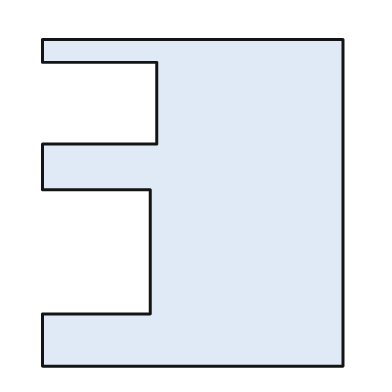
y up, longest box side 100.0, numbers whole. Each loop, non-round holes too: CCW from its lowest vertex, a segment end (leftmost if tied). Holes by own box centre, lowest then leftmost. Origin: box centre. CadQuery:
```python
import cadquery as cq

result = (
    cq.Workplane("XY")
    .moveTo(-46.0, -50.0)
    .lineTo(46.0, -50.0)
    .lineTo(46.0, 50.0)
    .lineTo(-46.0, 50.0)
    .lineTo(-46.0, 43.0)
    .lineTo(-11.0, 43.0)
    .lineTo(-11.0, 18.0)
    .lineTo(-46.0, 18.0)
    .lineTo(-46.0, 4.0)
    .lineTo(-13.0, 4.0)
    .lineTo(-13.0, -34.0)
    .lineTo(-46.0, -34.0)
    .close()
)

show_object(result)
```